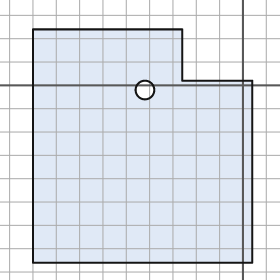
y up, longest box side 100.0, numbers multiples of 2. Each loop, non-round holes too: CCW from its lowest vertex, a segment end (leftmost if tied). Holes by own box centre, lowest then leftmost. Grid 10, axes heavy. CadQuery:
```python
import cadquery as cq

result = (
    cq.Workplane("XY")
    .moveTo(-90.0, -76.0)
    .lineTo(4.0, -76.0)
    .lineTo(4.0, 2.0)
    .lineTo(-26.0, 2.0)
    .lineTo(-26.0, 24.0)
    .lineTo(-90.0, 24.0)
    .close()
    .moveTo(-42.0, -2.0)
    .circle(4.0)
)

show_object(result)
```